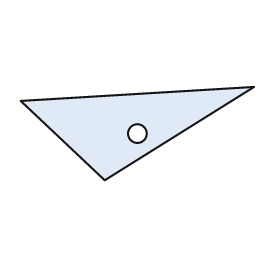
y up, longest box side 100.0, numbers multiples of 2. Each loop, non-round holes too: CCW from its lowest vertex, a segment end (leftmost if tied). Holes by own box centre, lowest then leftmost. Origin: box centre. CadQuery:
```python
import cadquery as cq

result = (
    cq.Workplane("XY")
    .moveTo(-14.0, -20.0)
    .lineTo(50.0, 20.0)
    .lineTo(-50.0, 14.0)
    .close()
    .moveTo(0.0, 0.0)
    .circle(4.0)
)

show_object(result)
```